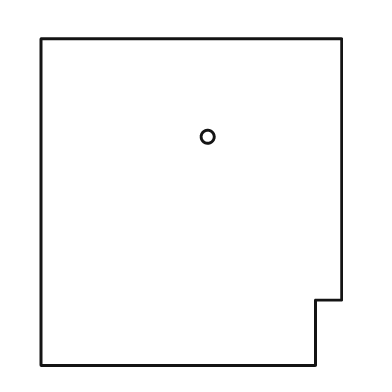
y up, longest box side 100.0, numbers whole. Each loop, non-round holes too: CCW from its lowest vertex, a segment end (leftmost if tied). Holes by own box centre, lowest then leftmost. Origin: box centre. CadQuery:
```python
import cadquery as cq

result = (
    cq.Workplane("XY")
    .moveTo(-46.0, -50.0)
    .lineTo(38.0, -50.0)
    .lineTo(38.0, -30.0)
    .lineTo(46.0, -30.0)
    .lineTo(46.0, 50.0)
    .lineTo(-46.0, 50.0)
    .close()
    .moveTo(5.0, 20.0)
    .circle(2.0)
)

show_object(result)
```